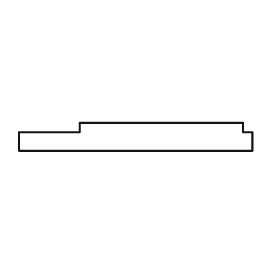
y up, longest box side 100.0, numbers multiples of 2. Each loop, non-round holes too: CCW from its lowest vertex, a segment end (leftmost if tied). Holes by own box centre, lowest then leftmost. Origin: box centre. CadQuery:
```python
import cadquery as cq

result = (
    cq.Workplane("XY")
    .moveTo(-50.0, -6.0)
    .lineTo(50.0, -6.0)
    .lineTo(50.0, 2.0)
    .lineTo(46.0, 2.0)
    .lineTo(46.0, 6.0)
    .lineTo(-24.0, 6.0)
    .lineTo(-24.0, 2.0)
    .lineTo(-50.0, 2.0)
    .close()
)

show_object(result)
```